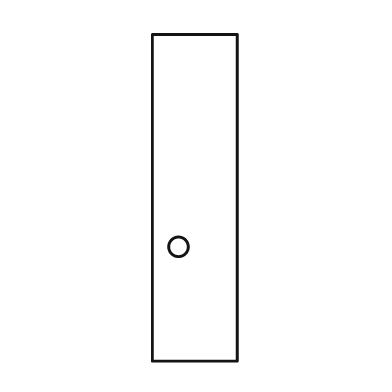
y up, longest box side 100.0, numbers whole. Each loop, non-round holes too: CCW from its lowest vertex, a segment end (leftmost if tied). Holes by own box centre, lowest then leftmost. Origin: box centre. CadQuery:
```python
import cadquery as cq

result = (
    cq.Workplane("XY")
    .moveTo(-13.0, -50.0)
    .lineTo(13.0, -50.0)
    .lineTo(13.0, 50.0)
    .lineTo(-13.0, 50.0)
    .close()
    .moveTo(-5.0, -15.0)
    .circle(3.0)
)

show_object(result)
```